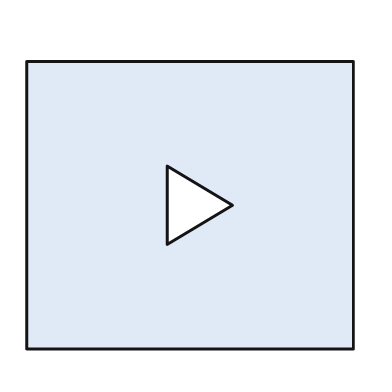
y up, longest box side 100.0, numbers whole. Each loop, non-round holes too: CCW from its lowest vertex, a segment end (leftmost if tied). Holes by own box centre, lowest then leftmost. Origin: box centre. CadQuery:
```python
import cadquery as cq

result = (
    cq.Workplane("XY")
    .moveTo(-50.0, -44.0)
    .lineTo(50.0, -44.0)
    .lineTo(50.0, 44.0)
    .lineTo(-50.0, 44.0)
    .close()
    .moveTo(-7.0, -12.0)
    .lineTo(13.0, 0.0)
    .lineTo(-7.0, 12.0)
    .close()
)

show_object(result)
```